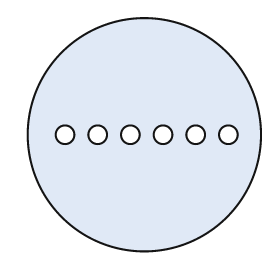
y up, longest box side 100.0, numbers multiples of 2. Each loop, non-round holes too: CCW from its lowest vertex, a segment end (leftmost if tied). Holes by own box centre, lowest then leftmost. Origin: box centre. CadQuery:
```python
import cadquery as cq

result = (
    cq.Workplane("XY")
    .moveTo(0.0, 0.0)
    .circle(50.0)
    .moveTo(-34.0, 0.0)
    .circle(4.0)
    .moveTo(-20.0, 0.0)
    .circle(4.0)
    .moveTo(-6.0, 0.0)
    .circle(4.0)
    .moveTo(8.0, 0.0)
    .circle(4.0)
    .moveTo(22.0, 0.0)
    .circle(4.0)
    .moveTo(36.0, 0.0)
    .circle(4.0)
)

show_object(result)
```